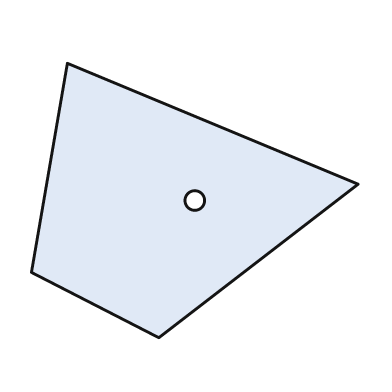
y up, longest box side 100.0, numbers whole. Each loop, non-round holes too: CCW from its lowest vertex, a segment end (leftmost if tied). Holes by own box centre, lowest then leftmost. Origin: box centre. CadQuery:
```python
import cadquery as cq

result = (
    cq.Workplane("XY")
    .moveTo(-11.0, -42.0)
    .lineTo(50.0, 5.0)
    .lineTo(-39.0, 42.0)
    .lineTo(-50.0, -22.0)
    .close()
    .moveTo(0.0, 0.0)
    .circle(3.0)
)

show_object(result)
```